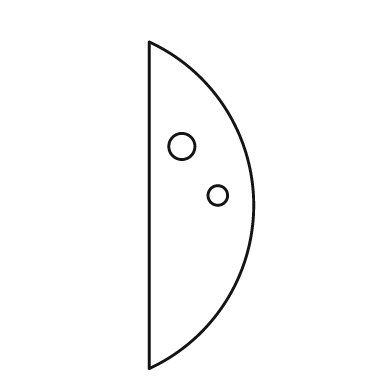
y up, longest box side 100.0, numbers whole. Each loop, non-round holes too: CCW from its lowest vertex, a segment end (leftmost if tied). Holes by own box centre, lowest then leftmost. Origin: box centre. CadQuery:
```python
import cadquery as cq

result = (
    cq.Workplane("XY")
    .moveTo(-16.0, -50.0)
    .threePointArc((16.0, 0.0), (-16.0, 50.0))
    .close()
    .moveTo(5.0, 3.0)
    .circle(3.0)
    .moveTo(-6.0, 18.0)
    .circle(4.0)
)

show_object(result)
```